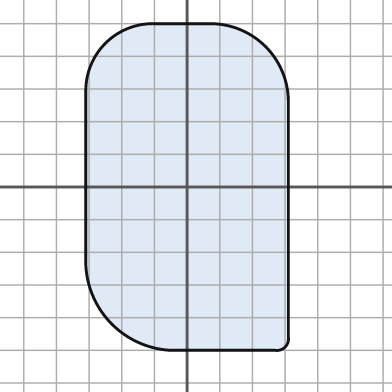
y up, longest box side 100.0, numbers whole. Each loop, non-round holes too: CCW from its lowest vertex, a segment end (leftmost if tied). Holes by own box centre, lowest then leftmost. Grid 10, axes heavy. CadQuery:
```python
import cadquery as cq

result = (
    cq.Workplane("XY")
    .moveTo(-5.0, -50.0)
    .lineTo(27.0, -50.0)
    .threePointArc((30.0, -49.0), (31.0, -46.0))
    .lineTo(31.0, 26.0)
    .threePointArc((24.0, 43.0), (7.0, 50.0))
    .lineTo(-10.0, 50.0)
    .threePointArc((-25.0, 44.0), (-31.0, 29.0))
    .lineTo(-31.0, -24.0)
    .threePointArc((-23.0, -42.0), (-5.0, -50.0))
    .close()
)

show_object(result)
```